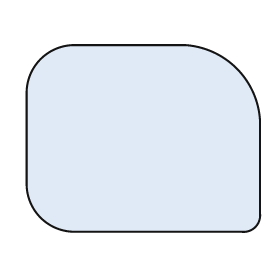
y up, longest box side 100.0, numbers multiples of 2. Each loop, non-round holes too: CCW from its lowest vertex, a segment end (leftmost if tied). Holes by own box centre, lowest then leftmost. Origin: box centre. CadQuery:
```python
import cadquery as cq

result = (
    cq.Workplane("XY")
    .moveTo(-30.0, -40.0)
    .lineTo(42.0, -40.0)
    .threePointArc((48.0, -38.0), (50.0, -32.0))
    .lineTo(50.0, 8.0)
    .threePointArc((40.0, 30.0), (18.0, 40.0))
    .lineTo(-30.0, 40.0)
    .threePointArc((-44.0, 34.0), (-50.0, 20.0))
    .lineTo(-50.0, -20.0)
    .threePointArc((-44.0, -34.0), (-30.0, -40.0))
    .close()
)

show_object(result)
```